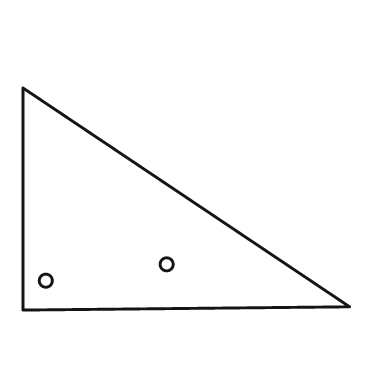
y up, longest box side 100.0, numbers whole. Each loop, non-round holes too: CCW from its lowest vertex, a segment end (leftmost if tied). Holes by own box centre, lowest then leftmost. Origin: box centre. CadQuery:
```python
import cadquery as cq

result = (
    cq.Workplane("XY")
    .moveTo(-50.0, -34.0)
    .lineTo(50.0, -33.0)
    .lineTo(-50.0, 34.0)
    .close()
    .moveTo(-43.0, -25.0)
    .circle(2.0)
    .moveTo(-6.0, -20.0)
    .circle(2.0)
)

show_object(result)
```